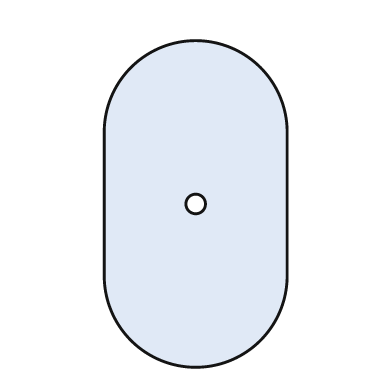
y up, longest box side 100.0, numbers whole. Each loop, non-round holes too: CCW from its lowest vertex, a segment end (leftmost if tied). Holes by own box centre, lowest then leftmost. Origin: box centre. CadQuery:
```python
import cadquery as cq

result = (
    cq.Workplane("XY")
    .moveTo(-28.0, -22.0)
    .threePointArc((0.0, -50.0), (28.0, -22.0))
    .lineTo(28.0, 22.0)
    .threePointArc((0.0, 50.0), (-28.0, 22.0))
    .close()
    .moveTo(0.0, 0.0)
    .circle(3.0)
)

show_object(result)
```